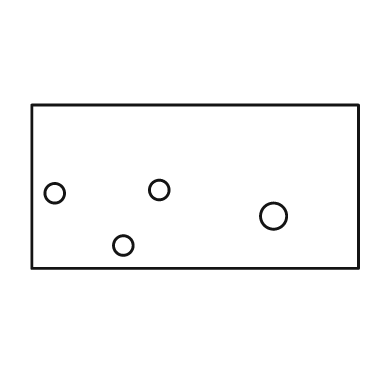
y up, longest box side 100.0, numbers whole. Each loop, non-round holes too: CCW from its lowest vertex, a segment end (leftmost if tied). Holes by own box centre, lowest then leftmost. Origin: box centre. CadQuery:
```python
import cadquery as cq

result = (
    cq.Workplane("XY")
    .moveTo(-50.0, -25.0)
    .lineTo(50.0, -25.0)
    .lineTo(50.0, 25.0)
    .lineTo(-50.0, 25.0)
    .close()
    .moveTo(-22.0, -18.0)
    .circle(3.0)
    .moveTo(24.0, -9.0)
    .circle(4.0)
    .moveTo(-43.0, -2.0)
    .circle(3.0)
    .moveTo(-11.0, -1.0)
    .circle(3.0)
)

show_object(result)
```